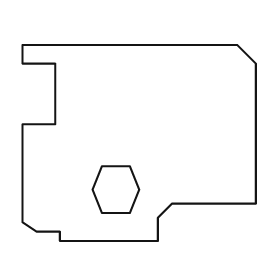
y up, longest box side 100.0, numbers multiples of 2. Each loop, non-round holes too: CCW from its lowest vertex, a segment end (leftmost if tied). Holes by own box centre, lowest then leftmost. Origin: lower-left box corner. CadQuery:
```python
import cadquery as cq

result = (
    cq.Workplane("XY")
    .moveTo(16.0, 0.0)
    .lineTo(58.0, 0.0)
    .lineTo(58.0, 10.0)
    .lineTo(64.0, 16.0)
    .lineTo(100.0, 16.0)
    .lineTo(100.0, 76.0)
    .lineTo(92.0, 84.0)
    .lineTo(0.0, 84.0)
    .lineTo(0.0, 76.0)
    .lineTo(14.0, 76.0)
    .lineTo(14.0, 50.0)
    .lineTo(0.0, 50.0)
    .lineTo(0.0, 8.0)
    .lineTo(6.0, 4.0)
    .lineTo(16.0, 4.0)
    .close()
    .moveTo(34.0, 12.0)
    .lineTo(46.0, 12.0)
    .lineTo(50.0, 22.0)
    .lineTo(46.0, 32.0)
    .lineTo(34.0, 32.0)
    .lineTo(30.0, 22.0)
    .close()
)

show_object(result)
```